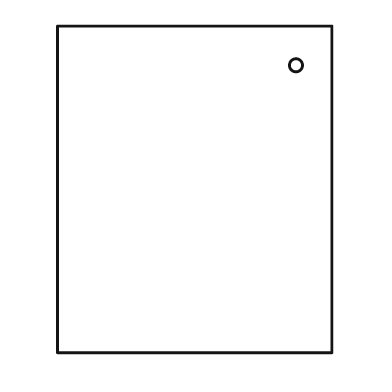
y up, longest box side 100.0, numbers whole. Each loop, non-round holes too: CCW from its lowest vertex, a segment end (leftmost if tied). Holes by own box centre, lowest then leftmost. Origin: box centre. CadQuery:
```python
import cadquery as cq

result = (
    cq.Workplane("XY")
    .moveTo(-42.0, -50.0)
    .lineTo(42.0, -50.0)
    .lineTo(42.0, 50.0)
    .lineTo(-42.0, 50.0)
    .close()
    .moveTo(31.0, 38.0)
    .circle(2.0)
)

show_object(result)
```